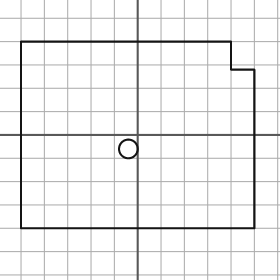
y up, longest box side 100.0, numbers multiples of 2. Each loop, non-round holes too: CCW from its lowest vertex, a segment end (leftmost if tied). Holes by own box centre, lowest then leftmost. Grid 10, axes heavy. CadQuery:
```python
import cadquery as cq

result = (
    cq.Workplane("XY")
    .moveTo(-50.0, -40.0)
    .lineTo(50.0, -40.0)
    .lineTo(50.0, 28.0)
    .lineTo(40.0, 28.0)
    .lineTo(40.0, 40.0)
    .lineTo(-50.0, 40.0)
    .close()
    .moveTo(-4.0, -6.0)
    .circle(4.0)
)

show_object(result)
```